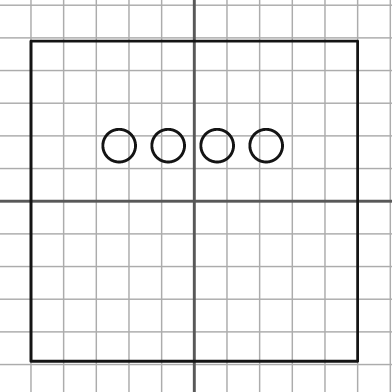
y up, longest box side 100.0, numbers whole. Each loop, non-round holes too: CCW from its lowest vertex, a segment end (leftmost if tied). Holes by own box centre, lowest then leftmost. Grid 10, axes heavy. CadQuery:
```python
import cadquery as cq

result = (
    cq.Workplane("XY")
    .moveTo(-50.0, -49.0)
    .lineTo(50.0, -49.0)
    .lineTo(50.0, 49.0)
    .lineTo(-50.0, 49.0)
    .close()
    .moveTo(-23.0, 17.0)
    .circle(5.0)
    .moveTo(-8.0, 17.0)
    .circle(5.0)
    .moveTo(7.0, 17.0)
    .circle(5.0)
    .moveTo(22.0, 17.0)
    .circle(5.0)
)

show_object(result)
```